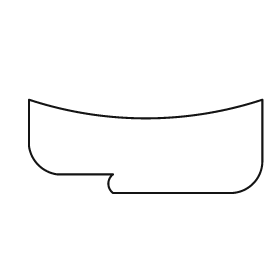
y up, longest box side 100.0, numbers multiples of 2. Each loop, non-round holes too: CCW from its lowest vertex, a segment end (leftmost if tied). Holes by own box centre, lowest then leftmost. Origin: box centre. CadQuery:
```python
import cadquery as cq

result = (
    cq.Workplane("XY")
    .moveTo(-14.0, -20.0)
    .lineTo(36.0, -20.0)
    .threePointArc((46.0, -16.0), (50.0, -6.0))
    .lineTo(50.0, 20.0)
    .threePointArc((0.0, 12.0), (-50.0, 20.0))
    .lineTo(-50.0, 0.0)
    .threePointArc((-46.0, -8.0), (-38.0, -12.0))
    .lineTo(-14.0, -12.0)
    .threePointArc((-16.0, -16.0), (-14.0, -20.0))
    .close()
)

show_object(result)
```